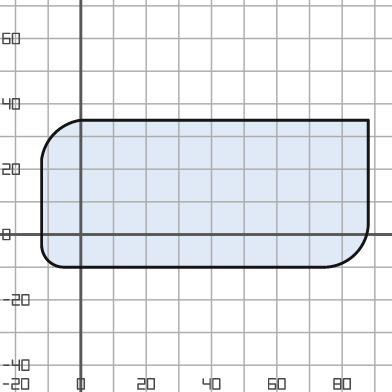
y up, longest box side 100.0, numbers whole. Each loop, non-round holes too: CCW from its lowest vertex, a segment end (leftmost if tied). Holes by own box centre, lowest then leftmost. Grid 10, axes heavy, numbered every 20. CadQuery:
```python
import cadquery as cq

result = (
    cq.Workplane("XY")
    .moveTo(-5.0, -10.0)
    .lineTo(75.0, -10.0)
    .threePointArc((84.0, -6.0), (88.0, 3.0))
    .lineTo(88.0, 35.0)
    .lineTo(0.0, 35.0)
    .threePointArc((-8.0, 31.0), (-12.0, 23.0))
    .lineTo(-12.0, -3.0)
    .threePointArc((-10.0, -8.0), (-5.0, -10.0))
    .close()
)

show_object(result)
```